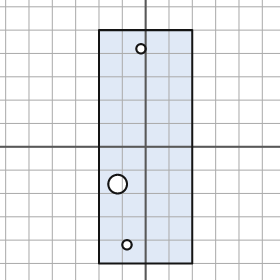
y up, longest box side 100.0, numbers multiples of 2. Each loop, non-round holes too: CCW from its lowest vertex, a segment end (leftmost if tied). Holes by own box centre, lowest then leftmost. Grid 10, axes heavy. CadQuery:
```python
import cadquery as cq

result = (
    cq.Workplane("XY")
    .moveTo(-20.0, -50.0)
    .lineTo(20.0, -50.0)
    .lineTo(20.0, 50.0)
    .lineTo(-20.0, 50.0)
    .close()
    .moveTo(-8.0, -42.0)
    .circle(2.0)
    .moveTo(-12.0, -16.0)
    .circle(4.0)
    .moveTo(-2.0, 42.0)
    .circle(2.0)
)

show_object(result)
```